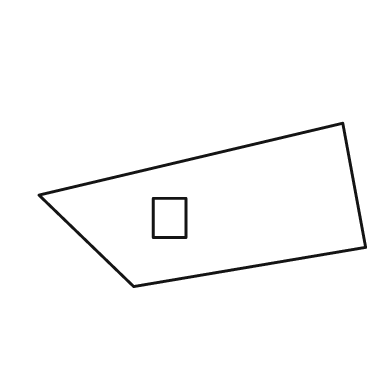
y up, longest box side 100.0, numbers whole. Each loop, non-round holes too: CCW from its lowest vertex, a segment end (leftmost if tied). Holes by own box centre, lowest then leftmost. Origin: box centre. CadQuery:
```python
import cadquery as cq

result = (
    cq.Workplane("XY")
    .moveTo(-21.0, -25.0)
    .lineTo(50.0, -13.0)
    .lineTo(43.0, 25.0)
    .lineTo(-50.0, 3.0)
    .close()
    .moveTo(-15.0, -10.0)
    .lineTo(-5.0, -10.0)
    .lineTo(-5.0, 2.0)
    .lineTo(-15.0, 2.0)
    .close()
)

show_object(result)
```